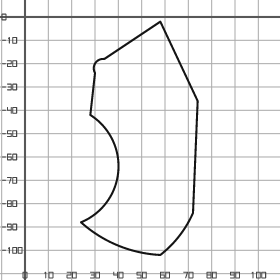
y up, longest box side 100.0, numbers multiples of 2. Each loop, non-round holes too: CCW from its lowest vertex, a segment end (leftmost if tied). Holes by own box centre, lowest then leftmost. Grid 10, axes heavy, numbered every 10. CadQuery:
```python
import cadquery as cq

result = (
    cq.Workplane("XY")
    .moveTo(58.0, -102.0)
    .threePointArc((66.0, -94.0), (72.0, -84.0))
    .lineTo(74.0, -36.0)
    .lineTo(58.0, -2.0)
    .lineTo(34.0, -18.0)
    .threePointArc((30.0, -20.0), (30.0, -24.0))
    .lineTo(28.0, -42.0)
    .threePointArc((40.0, -66.0), (24.0, -88.0))
    .threePointArc((40.0, -98.0), (58.0, -102.0))
    .close()
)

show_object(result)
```